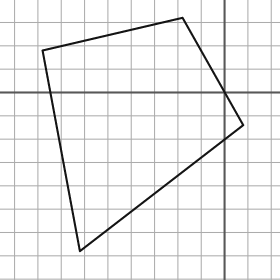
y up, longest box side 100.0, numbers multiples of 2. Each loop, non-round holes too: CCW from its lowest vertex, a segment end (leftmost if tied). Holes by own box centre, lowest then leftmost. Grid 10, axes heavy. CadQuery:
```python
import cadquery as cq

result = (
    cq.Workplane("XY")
    .moveTo(-62.0, -68.0)
    .lineTo(8.0, -14.0)
    .lineTo(-18.0, 32.0)
    .lineTo(-78.0, 18.0)
    .close()
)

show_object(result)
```